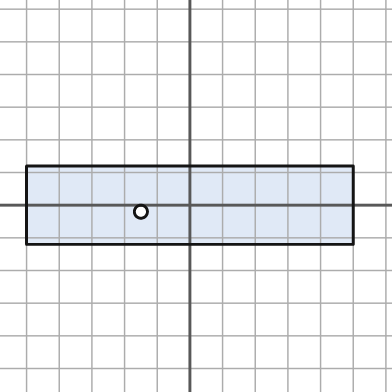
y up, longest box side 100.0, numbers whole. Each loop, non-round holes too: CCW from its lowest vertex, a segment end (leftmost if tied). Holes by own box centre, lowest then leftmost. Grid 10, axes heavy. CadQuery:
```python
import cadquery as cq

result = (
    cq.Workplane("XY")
    .moveTo(-50.0, -12.0)
    .lineTo(50.0, -12.0)
    .lineTo(50.0, 12.0)
    .lineTo(-50.0, 12.0)
    .close()
    .moveTo(-15.0, -2.0)
    .circle(2.0)
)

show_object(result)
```